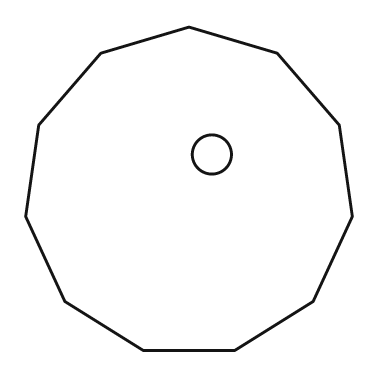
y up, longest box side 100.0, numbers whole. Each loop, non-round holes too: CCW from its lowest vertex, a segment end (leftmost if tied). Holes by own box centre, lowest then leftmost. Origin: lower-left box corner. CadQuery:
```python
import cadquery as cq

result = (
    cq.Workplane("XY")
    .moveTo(36.0, 0.0)
    .lineTo(64.0, 0.0)
    .lineTo(88.0, 15.0)
    .lineTo(100.0, 41.0)
    .lineTo(96.0, 69.0)
    .lineTo(77.0, 91.0)
    .lineTo(50.0, 99.0)
    .lineTo(23.0, 91.0)
    .lineTo(4.0, 69.0)
    .lineTo(0.0, 41.0)
    .lineTo(12.0, 15.0)
    .close()
    .moveTo(57.0, 60.0)
    .circle(6.0)
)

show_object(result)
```